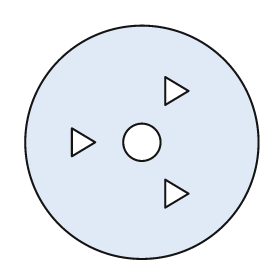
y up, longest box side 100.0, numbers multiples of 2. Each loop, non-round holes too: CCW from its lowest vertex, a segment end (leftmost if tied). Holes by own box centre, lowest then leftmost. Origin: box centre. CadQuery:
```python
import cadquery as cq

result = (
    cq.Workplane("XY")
    .moveTo(0.0, 0.0)
    .circle(50.0)
    .moveTo(10.0, -28.0)
    .lineTo(20.0, -22.0)
    .lineTo(10.0, -16.0)
    .close()
    .moveTo(-30.0, -6.0)
    .lineTo(-20.0, 0.0)
    .lineTo(-30.0, 6.0)
    .close()
    .moveTo(0.0, 0.0)
    .circle(8.0)
    .moveTo(10.0, 16.0)
    .lineTo(20.0, 22.0)
    .lineTo(10.0, 28.0)
    .close()
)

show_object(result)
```